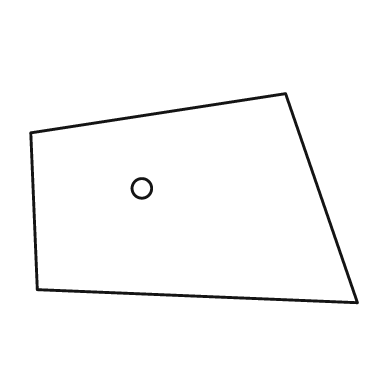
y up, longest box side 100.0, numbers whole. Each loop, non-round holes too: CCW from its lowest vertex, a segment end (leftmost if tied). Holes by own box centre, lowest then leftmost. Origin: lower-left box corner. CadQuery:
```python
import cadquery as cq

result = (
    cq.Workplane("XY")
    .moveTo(100.0, 0.0)
    .lineTo(78.0, 64.0)
    .lineTo(0.0, 52.0)
    .lineTo(2.0, 4.0)
    .close()
    .moveTo(34.0, 35.0)
    .circle(3.0)
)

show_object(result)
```